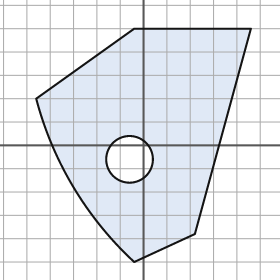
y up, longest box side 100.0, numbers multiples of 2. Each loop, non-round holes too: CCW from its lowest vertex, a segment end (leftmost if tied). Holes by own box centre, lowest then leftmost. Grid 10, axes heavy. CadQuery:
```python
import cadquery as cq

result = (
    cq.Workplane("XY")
    .moveTo(-4.0, -50.0)
    .lineTo(22.0, -38.0)
    .lineTo(46.0, 50.0)
    .lineTo(-4.0, 50.0)
    .lineTo(-46.0, 20.0)
    .threePointArc((-30.0, -18.0), (-4.0, -50.0))
    .close()
    .moveTo(-6.0, -6.0)
    .circle(10.0)
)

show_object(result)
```